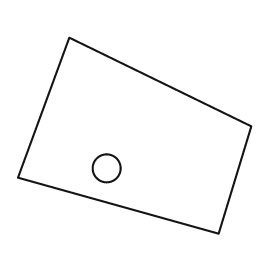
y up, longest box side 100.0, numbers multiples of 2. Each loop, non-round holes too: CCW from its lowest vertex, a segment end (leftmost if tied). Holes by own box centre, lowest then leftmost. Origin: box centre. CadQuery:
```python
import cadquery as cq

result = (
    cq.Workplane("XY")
    .moveTo(36.0, -42.0)
    .lineTo(50.0, 4.0)
    .lineTo(-28.0, 42.0)
    .lineTo(-50.0, -18.0)
    .close()
    .moveTo(-12.0, -14.0)
    .circle(6.0)
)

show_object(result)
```